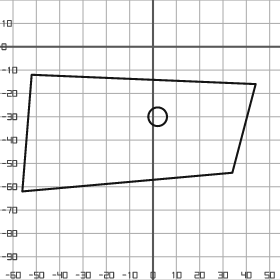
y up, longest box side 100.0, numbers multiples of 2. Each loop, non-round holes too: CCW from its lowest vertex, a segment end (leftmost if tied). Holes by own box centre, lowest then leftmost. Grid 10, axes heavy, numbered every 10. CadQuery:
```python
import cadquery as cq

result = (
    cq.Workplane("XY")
    .moveTo(-56.0, -62.0)
    .lineTo(34.0, -54.0)
    .lineTo(44.0, -16.0)
    .lineTo(-52.0, -12.0)
    .close()
    .moveTo(2.0, -30.0)
    .circle(4.0)
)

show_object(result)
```